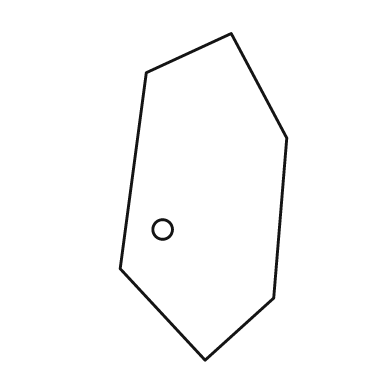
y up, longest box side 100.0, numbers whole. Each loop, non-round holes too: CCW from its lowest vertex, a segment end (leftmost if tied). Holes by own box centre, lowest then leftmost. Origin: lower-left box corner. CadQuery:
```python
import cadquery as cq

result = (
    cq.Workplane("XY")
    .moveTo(26.0, 0.0)
    .lineTo(47.0, 19.0)
    .lineTo(51.0, 68.0)
    .lineTo(34.0, 100.0)
    .lineTo(8.0, 88.0)
    .lineTo(0.0, 28.0)
    .close()
    .moveTo(13.0, 40.0)
    .circle(3.0)
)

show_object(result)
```